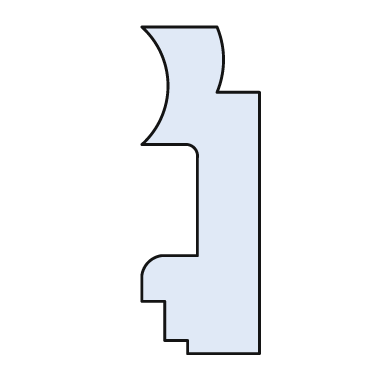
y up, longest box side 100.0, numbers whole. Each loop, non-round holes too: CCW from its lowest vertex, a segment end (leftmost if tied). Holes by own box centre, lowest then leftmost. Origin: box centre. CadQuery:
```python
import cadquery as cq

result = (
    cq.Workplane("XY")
    .moveTo(-4.0, -50.0)
    .lineTo(18.0, -50.0)
    .lineTo(18.0, 30.0)
    .lineTo(5.0, 30.0)
    .threePointArc((7.0, 40.0), (5.0, 50.0))
    .lineTo(-18.0, 50.0)
    .threePointArc((-10.0, 32.0), (-18.0, 14.0))
    .lineTo(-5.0, 14.0)
    .threePointArc((-2.0, 13.0), (-1.0, 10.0))
    .lineTo(-1.0, -20.0)
    .lineTo(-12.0, -20.0)
    .threePointArc((-16.0, -22.0), (-18.0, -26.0))
    .lineTo(-18.0, -34.0)
    .lineTo(-11.0, -34.0)
    .lineTo(-11.0, -46.0)
    .lineTo(-4.0, -46.0)
    .close()
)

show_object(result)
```